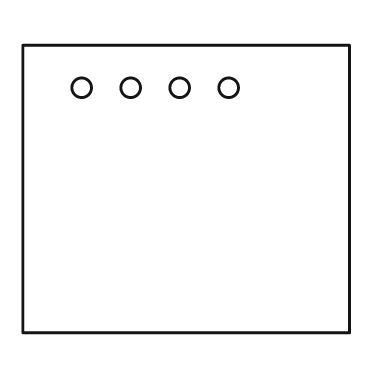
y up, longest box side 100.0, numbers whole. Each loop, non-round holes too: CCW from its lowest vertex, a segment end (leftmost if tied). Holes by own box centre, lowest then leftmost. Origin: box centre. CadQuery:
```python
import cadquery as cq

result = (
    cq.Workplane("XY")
    .moveTo(-50.0, -44.0)
    .lineTo(50.0, -44.0)
    .lineTo(50.0, 44.0)
    .lineTo(-50.0, 44.0)
    .close()
    .moveTo(-32.0, 31.0)
    .circle(3.0)
    .moveTo(-17.0, 31.0)
    .circle(3.0)
    .moveTo(-2.0, 31.0)
    .circle(3.0)
    .moveTo(13.0, 31.0)
    .circle(3.0)
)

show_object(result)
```